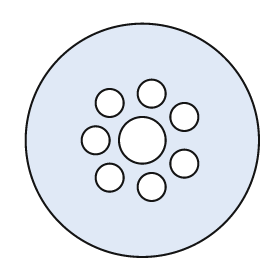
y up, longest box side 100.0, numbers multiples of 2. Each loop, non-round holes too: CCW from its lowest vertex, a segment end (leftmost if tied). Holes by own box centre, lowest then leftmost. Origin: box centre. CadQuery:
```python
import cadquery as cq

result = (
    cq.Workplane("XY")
    .moveTo(0.0, 0.0)
    .circle(50.0)
    .moveTo(4.0, -20.0)
    .circle(6.0)
    .moveTo(-14.0, -16.0)
    .circle(6.0)
    .moveTo(18.0, -10.0)
    .circle(6.0)
    .moveTo(-20.0, 0.0)
    .circle(6.0)
    .moveTo(0.0, 0.0)
    .circle(10.0)
    .moveTo(18.0, 10.0)
    .circle(6.0)
    .moveTo(-14.0, 16.0)
    .circle(6.0)
    .moveTo(4.0, 20.0)
    .circle(6.0)
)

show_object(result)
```